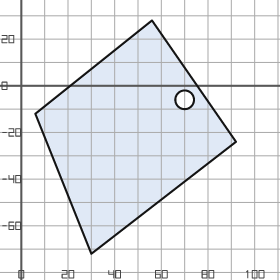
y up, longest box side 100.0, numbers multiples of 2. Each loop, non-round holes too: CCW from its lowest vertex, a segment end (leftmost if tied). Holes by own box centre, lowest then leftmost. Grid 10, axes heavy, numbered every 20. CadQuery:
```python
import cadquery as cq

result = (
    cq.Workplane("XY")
    .moveTo(30.0, -72.0)
    .lineTo(92.0, -24.0)
    .lineTo(56.0, 28.0)
    .lineTo(6.0, -12.0)
    .close()
    .moveTo(70.0, -6.0)
    .circle(4.0)
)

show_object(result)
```